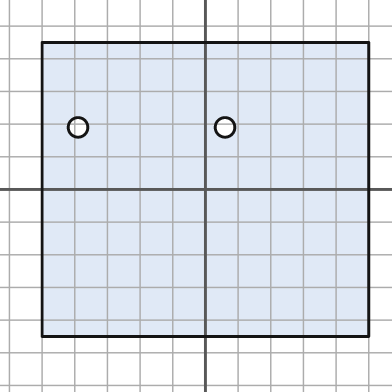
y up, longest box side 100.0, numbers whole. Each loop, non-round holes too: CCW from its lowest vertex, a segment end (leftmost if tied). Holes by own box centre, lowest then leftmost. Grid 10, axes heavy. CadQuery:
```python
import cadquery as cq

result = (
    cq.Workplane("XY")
    .moveTo(-50.0, -45.0)
    .lineTo(50.0, -45.0)
    .lineTo(50.0, 45.0)
    .lineTo(-50.0, 45.0)
    .close()
    .moveTo(-39.0, 19.0)
    .circle(3.0)
    .moveTo(6.0, 19.0)
    .circle(3.0)
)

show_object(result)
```